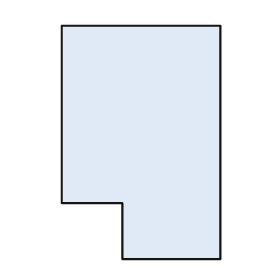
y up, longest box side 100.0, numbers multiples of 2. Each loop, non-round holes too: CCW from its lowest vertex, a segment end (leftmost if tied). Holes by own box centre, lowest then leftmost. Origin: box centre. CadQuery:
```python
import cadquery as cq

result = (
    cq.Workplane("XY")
    .moveTo(-8.0, -50.0)
    .lineTo(34.0, -50.0)
    .lineTo(34.0, 50.0)
    .lineTo(-34.0, 50.0)
    .lineTo(-34.0, -26.0)
    .lineTo(-8.0, -26.0)
    .close()
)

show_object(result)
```